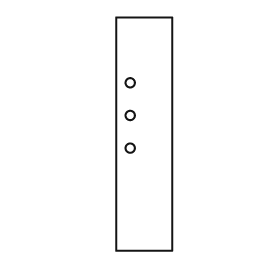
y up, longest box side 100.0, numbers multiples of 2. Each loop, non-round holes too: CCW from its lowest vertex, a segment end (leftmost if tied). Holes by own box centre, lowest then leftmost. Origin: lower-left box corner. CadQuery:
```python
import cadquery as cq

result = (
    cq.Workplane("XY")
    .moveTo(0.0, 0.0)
    .lineTo(24.0, 0.0)
    .lineTo(24.0, 100.0)
    .lineTo(0.0, 100.0)
    .close()
    .moveTo(6.0, 44.0)
    .circle(2.0)
    .moveTo(6.0, 58.0)
    .circle(2.0)
    .moveTo(6.0, 72.0)
    .circle(2.0)
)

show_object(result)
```